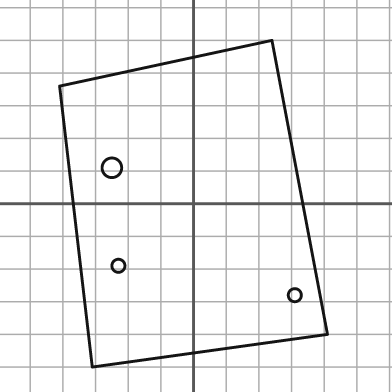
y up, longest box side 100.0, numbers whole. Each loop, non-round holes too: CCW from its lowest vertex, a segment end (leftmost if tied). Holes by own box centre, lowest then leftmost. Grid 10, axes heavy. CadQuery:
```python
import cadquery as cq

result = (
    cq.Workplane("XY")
    .moveTo(-31.0, -50.0)
    .lineTo(41.0, -40.0)
    .lineTo(24.0, 50.0)
    .lineTo(-41.0, 36.0)
    .close()
    .moveTo(31.0, -28.0)
    .circle(2.0)
    .moveTo(-23.0, -19.0)
    .circle(2.0)
    .moveTo(-25.0, 11.0)
    .circle(3.0)
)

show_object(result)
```